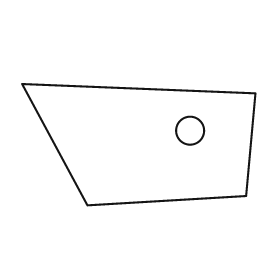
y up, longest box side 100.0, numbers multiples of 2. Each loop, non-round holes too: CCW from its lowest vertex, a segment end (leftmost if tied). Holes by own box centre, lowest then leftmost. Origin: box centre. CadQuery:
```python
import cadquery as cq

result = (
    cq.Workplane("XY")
    .moveTo(-22.0, -26.0)
    .lineTo(46.0, -22.0)
    .lineTo(50.0, 22.0)
    .lineTo(-50.0, 26.0)
    .close()
    .moveTo(22.0, 6.0)
    .circle(6.0)
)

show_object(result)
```